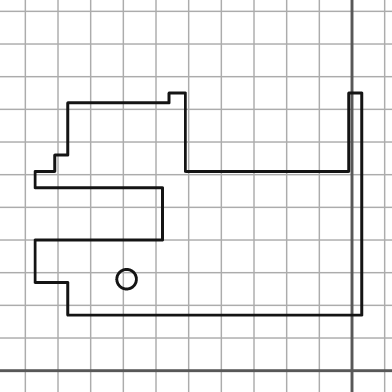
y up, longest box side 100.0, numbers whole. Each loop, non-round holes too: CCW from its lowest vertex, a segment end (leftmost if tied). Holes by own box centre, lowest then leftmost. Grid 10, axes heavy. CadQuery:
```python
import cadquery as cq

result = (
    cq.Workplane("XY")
    .moveTo(-87.0, 17.0)
    .lineTo(3.0, 17.0)
    .lineTo(3.0, 85.0)
    .lineTo(-1.0, 85.0)
    .lineTo(-1.0, 61.0)
    .lineTo(-51.0, 61.0)
    .lineTo(-51.0, 85.0)
    .lineTo(-56.0, 85.0)
    .lineTo(-56.0, 82.0)
    .lineTo(-87.0, 82.0)
    .lineTo(-87.0, 66.0)
    .lineTo(-91.0, 66.0)
    .lineTo(-91.0, 61.0)
    .lineTo(-97.0, 61.0)
    .lineTo(-97.0, 56.0)
    .lineTo(-58.0, 56.0)
    .lineTo(-58.0, 40.0)
    .lineTo(-97.0, 40.0)
    .lineTo(-97.0, 27.0)
    .lineTo(-87.0, 27.0)
    .close()
    .moveTo(-69.0, 28.0)
    .circle(3.0)
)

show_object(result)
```